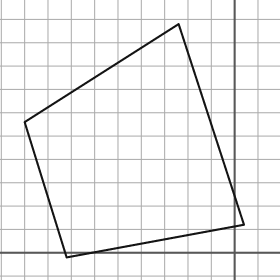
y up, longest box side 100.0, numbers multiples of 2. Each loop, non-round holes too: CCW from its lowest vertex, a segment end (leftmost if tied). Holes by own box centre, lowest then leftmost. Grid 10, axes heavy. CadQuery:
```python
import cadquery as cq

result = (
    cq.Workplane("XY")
    .moveTo(-72.0, -2.0)
    .lineTo(4.0, 12.0)
    .lineTo(-24.0, 98.0)
    .lineTo(-90.0, 56.0)
    .close()
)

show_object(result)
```